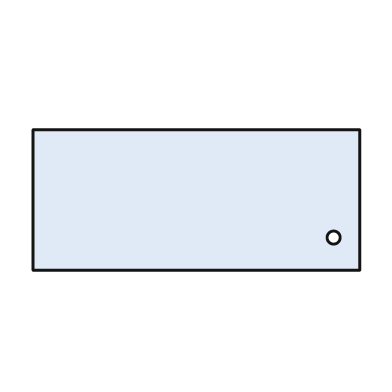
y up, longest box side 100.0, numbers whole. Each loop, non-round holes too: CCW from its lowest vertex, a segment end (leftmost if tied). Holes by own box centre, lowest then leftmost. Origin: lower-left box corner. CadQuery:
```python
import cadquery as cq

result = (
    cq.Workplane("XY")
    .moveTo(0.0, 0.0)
    .lineTo(100.0, 0.0)
    .lineTo(100.0, 43.0)
    .lineTo(0.0, 43.0)
    .close()
    .moveTo(92.0, 10.0)
    .circle(2.0)
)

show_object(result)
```